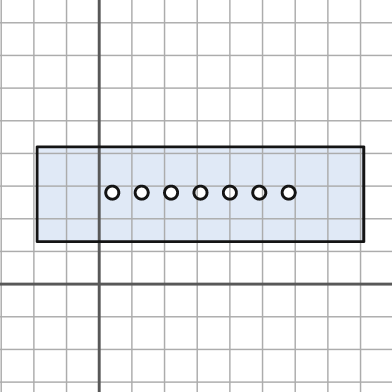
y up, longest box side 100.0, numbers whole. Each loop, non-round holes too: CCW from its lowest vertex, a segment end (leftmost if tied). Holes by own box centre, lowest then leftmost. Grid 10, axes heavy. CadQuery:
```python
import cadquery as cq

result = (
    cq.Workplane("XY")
    .moveTo(-19.0, 13.0)
    .lineTo(81.0, 13.0)
    .lineTo(81.0, 42.0)
    .lineTo(-19.0, 42.0)
    .close()
    .moveTo(4.0, 28.0)
    .circle(2.0)
    .moveTo(13.0, 28.0)
    .circle(2.0)
    .moveTo(22.0, 28.0)
    .circle(2.0)
    .moveTo(31.0, 28.0)
    .circle(2.0)
    .moveTo(40.0, 28.0)
    .circle(2.0)
    .moveTo(49.0, 28.0)
    .circle(2.0)
    .moveTo(58.0, 28.0)
    .circle(2.0)
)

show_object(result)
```